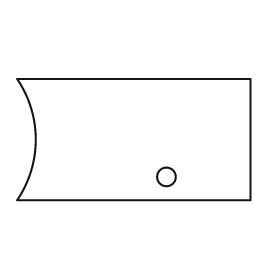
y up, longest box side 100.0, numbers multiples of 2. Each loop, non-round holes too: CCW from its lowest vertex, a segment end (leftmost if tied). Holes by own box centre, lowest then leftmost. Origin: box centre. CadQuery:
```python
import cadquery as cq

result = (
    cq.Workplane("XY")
    .moveTo(-50.0, -26.0)
    .lineTo(50.0, -26.0)
    .lineTo(50.0, 26.0)
    .lineTo(-50.0, 26.0)
    .threePointArc((-42.0, 0.0), (-50.0, -26.0))
    .close()
    .moveTo(14.0, -16.0)
    .circle(4.0)
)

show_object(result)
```